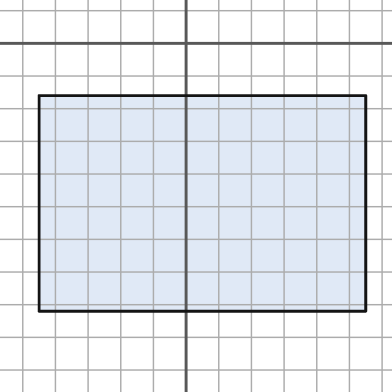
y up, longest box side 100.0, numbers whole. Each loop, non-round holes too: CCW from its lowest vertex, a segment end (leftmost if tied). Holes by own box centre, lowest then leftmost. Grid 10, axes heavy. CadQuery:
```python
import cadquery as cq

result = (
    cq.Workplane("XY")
    .moveTo(-45.0, -82.0)
    .lineTo(55.0, -82.0)
    .lineTo(55.0, -16.0)
    .lineTo(-45.0, -16.0)
    .close()
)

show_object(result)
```